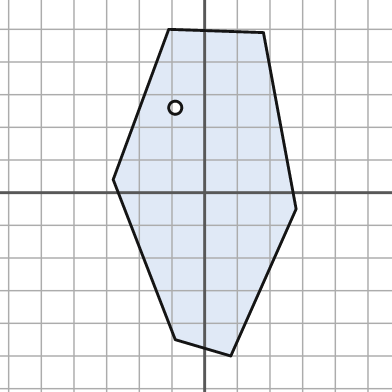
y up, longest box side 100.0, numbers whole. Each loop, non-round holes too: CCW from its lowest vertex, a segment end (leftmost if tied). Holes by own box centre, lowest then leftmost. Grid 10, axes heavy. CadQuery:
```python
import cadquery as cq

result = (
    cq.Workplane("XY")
    .moveTo(8.0, -50.0)
    .lineTo(28.0, -5.0)
    .lineTo(18.0, 49.0)
    .lineTo(-11.0, 50.0)
    .lineTo(-28.0, 4.0)
    .lineTo(-9.0, -45.0)
    .close()
    .moveTo(-9.0, 26.0)
    .circle(2.0)
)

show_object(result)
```